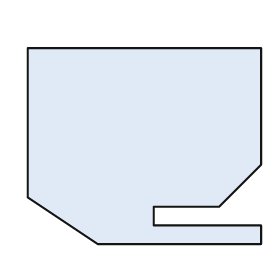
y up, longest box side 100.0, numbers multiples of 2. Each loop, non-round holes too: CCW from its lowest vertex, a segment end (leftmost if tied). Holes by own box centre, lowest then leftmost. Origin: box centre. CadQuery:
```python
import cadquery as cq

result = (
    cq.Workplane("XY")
    .moveTo(-20.0, -42.0)
    .lineTo(50.0, -42.0)
    .lineTo(50.0, -34.0)
    .lineTo(4.0, -34.0)
    .lineTo(4.0, -26.0)
    .lineTo(32.0, -26.0)
    .lineTo(50.0, -8.0)
    .lineTo(50.0, 42.0)
    .lineTo(-50.0, 42.0)
    .lineTo(-50.0, -22.0)
    .close()
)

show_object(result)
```